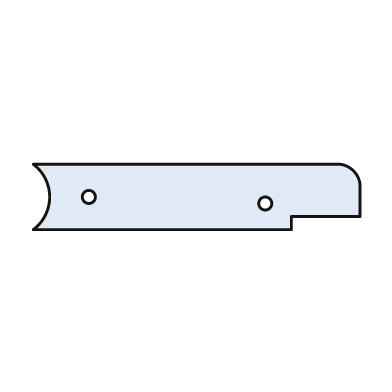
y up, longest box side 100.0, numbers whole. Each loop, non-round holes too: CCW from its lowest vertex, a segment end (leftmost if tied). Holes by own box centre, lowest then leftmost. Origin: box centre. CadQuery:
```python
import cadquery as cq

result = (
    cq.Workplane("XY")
    .moveTo(-50.0, -10.0)
    .lineTo(29.0, -10.0)
    .lineTo(29.0, -6.0)
    .lineTo(50.0, -6.0)
    .lineTo(50.0, 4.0)
    .threePointArc((48.0, 8.0), (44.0, 10.0))
    .lineTo(-50.0, 10.0)
    .threePointArc((-45.0, 0.0), (-50.0, -10.0))
    .close()
    .moveTo(21.0, -2.0)
    .circle(2.0)
    .moveTo(-33.0, 0.0)
    .circle(2.0)
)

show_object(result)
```